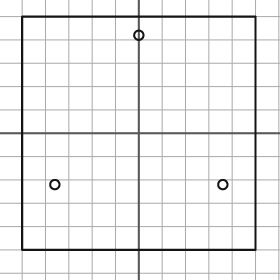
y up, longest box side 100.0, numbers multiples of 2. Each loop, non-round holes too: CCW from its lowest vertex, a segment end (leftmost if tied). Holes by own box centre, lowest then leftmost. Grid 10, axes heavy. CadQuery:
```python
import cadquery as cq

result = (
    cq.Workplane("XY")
    .moveTo(-50.0, -50.0)
    .lineTo(50.0, -50.0)
    .lineTo(50.0, 50.0)
    .lineTo(-50.0, 50.0)
    .close()
    .moveTo(-36.0, -22.0)
    .circle(2.0)
    .moveTo(36.0, -22.0)
    .circle(2.0)
    .moveTo(0.0, 42.0)
    .circle(2.0)
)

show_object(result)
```